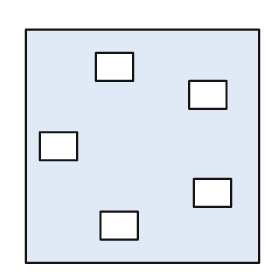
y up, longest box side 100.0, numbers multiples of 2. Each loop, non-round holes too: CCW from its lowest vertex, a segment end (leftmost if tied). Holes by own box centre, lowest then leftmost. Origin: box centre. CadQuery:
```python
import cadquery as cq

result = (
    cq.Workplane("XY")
    .moveTo(-50.0, -50.0)
    .lineTo(50.0, -50.0)
    .lineTo(50.0, 50.0)
    .lineTo(-50.0, 50.0)
    .close()
    .moveTo(-18.0, -40.0)
    .lineTo(-2.0, -40.0)
    .lineTo(-2.0, -28.0)
    .lineTo(-18.0, -28.0)
    .close()
    .moveTo(22.0, -26.0)
    .lineTo(38.0, -26.0)
    .lineTo(38.0, -14.0)
    .lineTo(22.0, -14.0)
    .close()
    .moveTo(-44.0, -6.0)
    .lineTo(-28.0, -6.0)
    .lineTo(-28.0, 6.0)
    .lineTo(-44.0, 6.0)
    .close()
    .moveTo(20.0, 16.0)
    .lineTo(36.0, 16.0)
    .lineTo(36.0, 28.0)
    .lineTo(20.0, 28.0)
    .close()
    .moveTo(-20.0, 28.0)
    .lineTo(-4.0, 28.0)
    .lineTo(-4.0, 40.0)
    .lineTo(-20.0, 40.0)
    .close()
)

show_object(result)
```